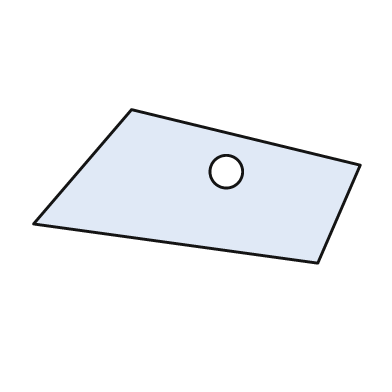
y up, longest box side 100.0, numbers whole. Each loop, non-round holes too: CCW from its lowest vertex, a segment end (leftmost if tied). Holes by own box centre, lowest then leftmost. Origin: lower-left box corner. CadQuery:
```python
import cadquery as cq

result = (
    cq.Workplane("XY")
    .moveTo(87.0, 0.0)
    .lineTo(100.0, 30.0)
    .lineTo(30.0, 47.0)
    .lineTo(0.0, 12.0)
    .close()
    .moveTo(59.0, 28.0)
    .circle(5.0)
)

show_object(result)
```